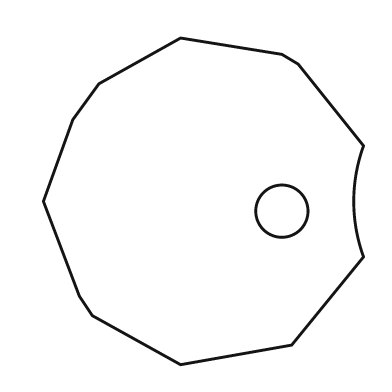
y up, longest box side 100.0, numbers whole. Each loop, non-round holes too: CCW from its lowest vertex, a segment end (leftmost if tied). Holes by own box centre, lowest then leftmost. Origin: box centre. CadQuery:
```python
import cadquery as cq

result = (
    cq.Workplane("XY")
    .moveTo(-7.0, -50.0)
    .lineTo(27.0, -44.0)
    .lineTo(49.0, -17.0)
    .threePointArc((46.0, 0.0), (49.0, 17.0))
    .lineTo(29.0, 42.0)
    .lineTo(24.0, 45.0)
    .lineTo(-7.0, 50.0)
    .lineTo(-32.0, 36.0)
    .lineTo(-40.0, 25.0)
    .lineTo(-49.0, 0.0)
    .lineTo(-38.0, -29.0)
    .lineTo(-34.0, -35.0)
    .close()
    .moveTo(24.0, -3.0)
    .circle(8.0)
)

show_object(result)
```